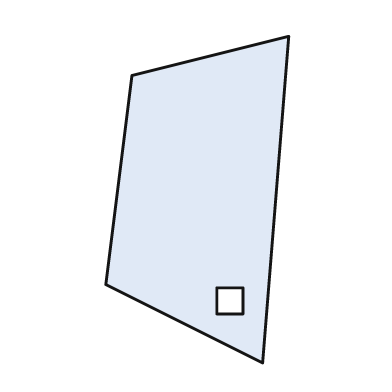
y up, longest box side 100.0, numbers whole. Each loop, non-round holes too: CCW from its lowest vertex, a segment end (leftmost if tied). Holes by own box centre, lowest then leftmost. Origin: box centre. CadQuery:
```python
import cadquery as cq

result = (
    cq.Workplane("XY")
    .moveTo(20.0, -50.0)
    .lineTo(28.0, 50.0)
    .lineTo(-20.0, 38.0)
    .lineTo(-28.0, -26.0)
    .close()
    .moveTo(6.0, -35.0)
    .lineTo(14.0, -35.0)
    .lineTo(14.0, -27.0)
    .lineTo(6.0, -27.0)
    .close()
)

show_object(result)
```